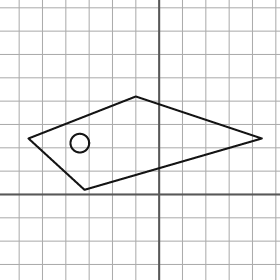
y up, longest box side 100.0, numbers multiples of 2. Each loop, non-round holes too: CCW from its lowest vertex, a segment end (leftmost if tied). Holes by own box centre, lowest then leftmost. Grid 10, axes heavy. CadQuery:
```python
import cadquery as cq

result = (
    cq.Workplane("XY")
    .moveTo(-32.0, 2.0)
    .lineTo(44.0, 24.0)
    .lineTo(-10.0, 42.0)
    .lineTo(-56.0, 24.0)
    .close()
    .moveTo(-34.0, 22.0)
    .circle(4.0)
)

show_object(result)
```